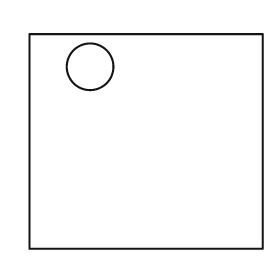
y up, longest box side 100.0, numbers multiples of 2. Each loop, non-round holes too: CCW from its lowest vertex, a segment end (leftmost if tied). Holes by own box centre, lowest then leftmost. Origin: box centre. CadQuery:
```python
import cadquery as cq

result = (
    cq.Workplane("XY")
    .moveTo(-50.0, -46.0)
    .lineTo(50.0, -46.0)
    .lineTo(50.0, 46.0)
    .lineTo(-50.0, 46.0)
    .close()
    .moveTo(-24.0, 32.0)
    .circle(10.0)
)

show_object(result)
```